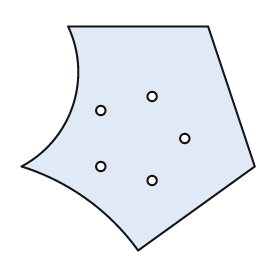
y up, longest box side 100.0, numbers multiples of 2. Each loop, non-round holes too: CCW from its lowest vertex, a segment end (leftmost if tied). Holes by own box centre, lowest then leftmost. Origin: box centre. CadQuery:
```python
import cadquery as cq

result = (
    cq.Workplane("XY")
    .moveTo(0.0, -48.0)
    .lineTo(50.0, -12.0)
    .lineTo(30.0, 48.0)
    .lineTo(-30.0, 48.0)
    .threePointArc((-28.0, 14.0), (-50.0, -12.0))
    .threePointArc((-22.0, -26.0), (0.0, -48.0))
    .close()
    .moveTo(6.0, -18.0)
    .circle(2.0)
    .moveTo(-16.0, -12.0)
    .circle(2.0)
    .moveTo(20.0, 0.0)
    .circle(2.0)
    .moveTo(-16.0, 12.0)
    .circle(2.0)
    .moveTo(6.0, 18.0)
    .circle(2.0)
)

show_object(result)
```